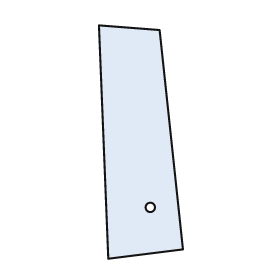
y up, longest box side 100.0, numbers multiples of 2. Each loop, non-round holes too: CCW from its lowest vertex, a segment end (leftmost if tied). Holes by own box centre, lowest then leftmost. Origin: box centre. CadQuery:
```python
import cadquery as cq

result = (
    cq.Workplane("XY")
    .moveTo(-14.0, -50.0)
    .lineTo(18.0, -46.0)
    .lineTo(8.0, 48.0)
    .lineTo(-18.0, 50.0)
    .close()
    .moveTo(4.0, -28.0)
    .circle(2.0)
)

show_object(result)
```